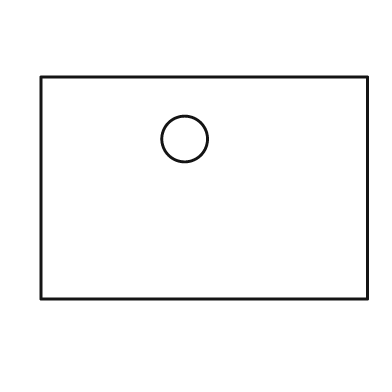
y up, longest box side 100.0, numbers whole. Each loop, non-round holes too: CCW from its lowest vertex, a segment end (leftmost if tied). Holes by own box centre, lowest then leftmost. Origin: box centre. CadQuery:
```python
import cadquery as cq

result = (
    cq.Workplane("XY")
    .moveTo(-50.0, -34.0)
    .lineTo(50.0, -34.0)
    .lineTo(50.0, 34.0)
    .lineTo(-50.0, 34.0)
    .close()
    .moveTo(-6.0, 15.0)
    .circle(7.0)
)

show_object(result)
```